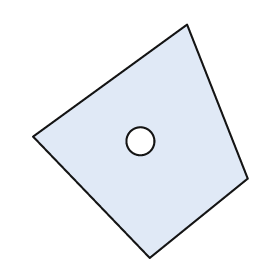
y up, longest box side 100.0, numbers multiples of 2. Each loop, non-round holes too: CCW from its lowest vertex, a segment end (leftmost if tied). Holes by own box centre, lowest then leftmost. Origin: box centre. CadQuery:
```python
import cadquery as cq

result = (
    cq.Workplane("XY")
    .moveTo(4.0, -50.0)
    .lineTo(46.0, -16.0)
    .lineTo(20.0, 50.0)
    .lineTo(-46.0, 2.0)
    .close()
    .moveTo(0.0, 0.0)
    .circle(6.0)
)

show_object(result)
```